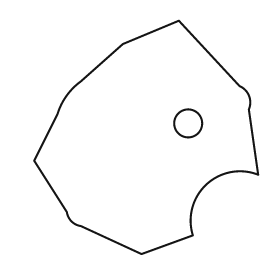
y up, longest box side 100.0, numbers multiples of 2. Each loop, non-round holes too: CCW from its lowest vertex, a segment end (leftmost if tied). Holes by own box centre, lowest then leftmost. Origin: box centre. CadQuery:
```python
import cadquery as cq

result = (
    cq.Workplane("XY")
    .moveTo(-2.0, -50.0)
    .lineTo(20.0, -42.0)
    .threePointArc((26.0, -20.0), (48.0, -16.0))
    .lineTo(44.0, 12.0)
    .threePointArc((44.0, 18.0), (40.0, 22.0))
    .lineTo(14.0, 50.0)
    .lineTo(-10.0, 40.0)
    .lineTo(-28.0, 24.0)
    .threePointArc((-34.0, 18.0), (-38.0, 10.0))
    .lineTo(-48.0, -10.0)
    .lineTo(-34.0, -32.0)
    .threePointArc((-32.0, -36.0), (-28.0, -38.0))
    .close()
    .moveTo(18.0, 6.0)
    .circle(6.0)
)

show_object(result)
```